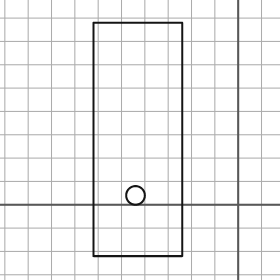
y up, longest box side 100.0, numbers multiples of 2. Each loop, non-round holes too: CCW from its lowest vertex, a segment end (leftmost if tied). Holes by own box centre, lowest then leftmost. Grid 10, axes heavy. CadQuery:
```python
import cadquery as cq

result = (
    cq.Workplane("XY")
    .moveTo(-62.0, -22.0)
    .lineTo(-24.0, -22.0)
    .lineTo(-24.0, 78.0)
    .lineTo(-62.0, 78.0)
    .close()
    .moveTo(-44.0, 4.0)
    .circle(4.0)
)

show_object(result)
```